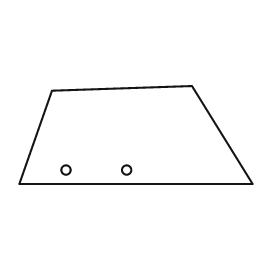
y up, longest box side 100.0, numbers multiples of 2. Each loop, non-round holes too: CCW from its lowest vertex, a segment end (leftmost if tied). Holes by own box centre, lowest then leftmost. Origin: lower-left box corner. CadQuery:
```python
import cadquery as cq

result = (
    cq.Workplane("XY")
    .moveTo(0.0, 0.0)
    .lineTo(100.0, 0.0)
    .lineTo(74.0, 42.0)
    .lineTo(14.0, 40.0)
    .close()
    .moveTo(20.0, 6.0)
    .circle(2.0)
    .moveTo(46.0, 6.0)
    .circle(2.0)
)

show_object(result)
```